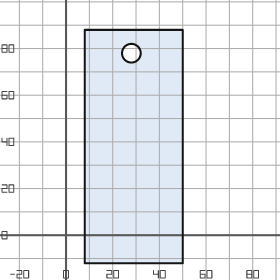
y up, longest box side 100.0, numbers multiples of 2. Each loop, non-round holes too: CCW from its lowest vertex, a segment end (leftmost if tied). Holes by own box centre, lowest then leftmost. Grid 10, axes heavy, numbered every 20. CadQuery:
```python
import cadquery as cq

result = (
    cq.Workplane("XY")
    .moveTo(8.0, -12.0)
    .lineTo(50.0, -12.0)
    .lineTo(50.0, 88.0)
    .lineTo(8.0, 88.0)
    .close()
    .moveTo(28.0, 78.0)
    .circle(4.0)
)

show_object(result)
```